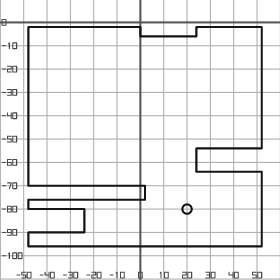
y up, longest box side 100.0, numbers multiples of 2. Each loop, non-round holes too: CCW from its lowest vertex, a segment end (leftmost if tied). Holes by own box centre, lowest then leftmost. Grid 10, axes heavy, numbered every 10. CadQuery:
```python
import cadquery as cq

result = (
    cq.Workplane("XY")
    .moveTo(-48.0, -96.0)
    .lineTo(52.0, -96.0)
    .lineTo(52.0, -64.0)
    .lineTo(24.0, -64.0)
    .lineTo(24.0, -54.0)
    .lineTo(52.0, -54.0)
    .lineTo(52.0, -2.0)
    .lineTo(24.0, -2.0)
    .lineTo(24.0, -6.0)
    .lineTo(0.0, -6.0)
    .lineTo(0.0, -2.0)
    .lineTo(-48.0, -2.0)
    .lineTo(-48.0, -70.0)
    .lineTo(2.0, -70.0)
    .lineTo(2.0, -76.0)
    .lineTo(-48.0, -76.0)
    .lineTo(-48.0, -80.0)
    .lineTo(-24.0, -80.0)
    .lineTo(-24.0, -90.0)
    .lineTo(-48.0, -90.0)
    .close()
    .moveTo(20.0, -80.0)
    .circle(2.0)
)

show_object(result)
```